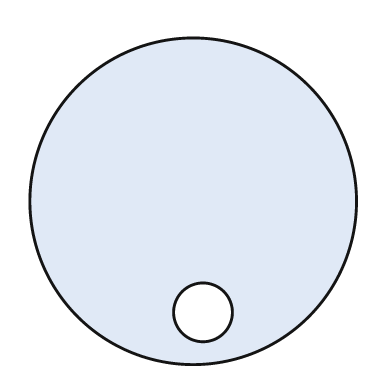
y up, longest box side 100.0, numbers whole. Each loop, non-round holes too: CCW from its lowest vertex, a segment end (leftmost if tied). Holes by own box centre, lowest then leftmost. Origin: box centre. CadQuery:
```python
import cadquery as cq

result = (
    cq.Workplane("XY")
    .moveTo(0.0, 0.0)
    .circle(50.0)
    .moveTo(3.0, -34.0)
    .circle(9.0)
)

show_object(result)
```